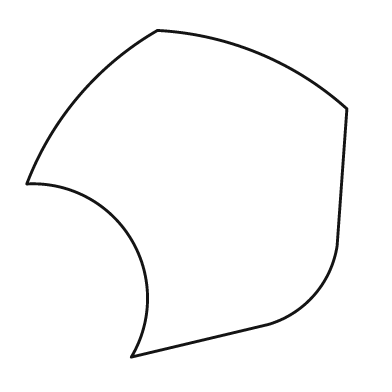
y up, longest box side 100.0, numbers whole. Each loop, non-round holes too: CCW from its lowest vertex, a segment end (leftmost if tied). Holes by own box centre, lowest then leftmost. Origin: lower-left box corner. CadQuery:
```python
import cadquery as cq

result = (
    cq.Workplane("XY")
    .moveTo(32.0, 0.0)
    .lineTo(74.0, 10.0)
    .threePointArc((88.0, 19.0), (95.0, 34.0))
    .lineTo(98.0, 76.0)
    .threePointArc((71.0, 93.0), (40.0, 100.0))
    .threePointArc((16.0, 80.0), (0.0, 53.0))
    .threePointArc((32.0, 36.0), (32.0, 0.0))
    .close()
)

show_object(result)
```